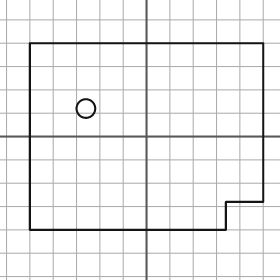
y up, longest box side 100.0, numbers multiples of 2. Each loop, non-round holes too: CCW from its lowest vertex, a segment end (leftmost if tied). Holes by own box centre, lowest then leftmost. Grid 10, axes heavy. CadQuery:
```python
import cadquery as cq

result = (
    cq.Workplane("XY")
    .moveTo(-50.0, -40.0)
    .lineTo(34.0, -40.0)
    .lineTo(34.0, -28.0)
    .lineTo(50.0, -28.0)
    .lineTo(50.0, 40.0)
    .lineTo(-50.0, 40.0)
    .close()
    .moveTo(-26.0, 12.0)
    .circle(4.0)
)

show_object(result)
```